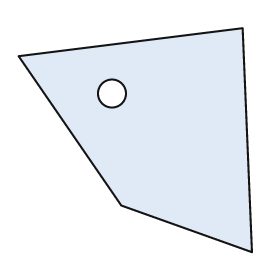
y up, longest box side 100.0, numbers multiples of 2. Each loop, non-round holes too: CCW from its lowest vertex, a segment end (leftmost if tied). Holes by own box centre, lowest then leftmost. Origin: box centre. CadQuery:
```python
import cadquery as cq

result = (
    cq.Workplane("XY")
    .moveTo(50.0, -48.0)
    .lineTo(46.0, 48.0)
    .lineTo(-50.0, 36.0)
    .lineTo(-6.0, -28.0)
    .close()
    .moveTo(-10.0, 20.0)
    .circle(6.0)
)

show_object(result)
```